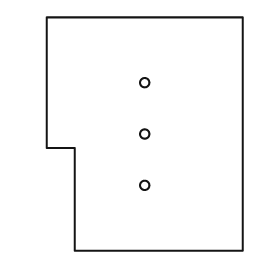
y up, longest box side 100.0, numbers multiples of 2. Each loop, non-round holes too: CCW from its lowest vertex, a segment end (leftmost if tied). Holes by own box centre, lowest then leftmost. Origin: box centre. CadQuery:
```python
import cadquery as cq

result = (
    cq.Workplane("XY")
    .moveTo(-30.0, -50.0)
    .lineTo(42.0, -50.0)
    .lineTo(42.0, 50.0)
    .lineTo(-42.0, 50.0)
    .lineTo(-42.0, -6.0)
    .lineTo(-30.0, -6.0)
    .close()
    .moveTo(0.0, -22.0)
    .circle(2.0)
    .moveTo(0.0, 0.0)
    .circle(2.0)
    .moveTo(0.0, 22.0)
    .circle(2.0)
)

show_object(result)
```